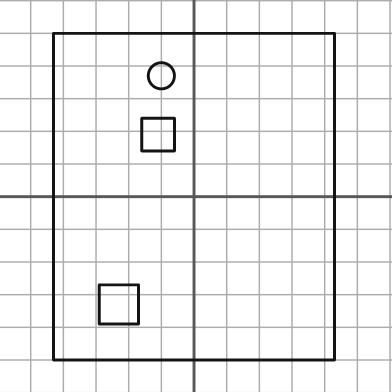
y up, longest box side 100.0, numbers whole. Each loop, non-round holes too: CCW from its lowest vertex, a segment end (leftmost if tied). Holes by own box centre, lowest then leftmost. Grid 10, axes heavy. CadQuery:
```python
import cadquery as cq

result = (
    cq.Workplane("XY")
    .moveTo(-43.0, -50.0)
    .lineTo(43.0, -50.0)
    .lineTo(43.0, 50.0)
    .lineTo(-43.0, 50.0)
    .close()
    .moveTo(-29.0, -39.0)
    .lineTo(-17.0, -39.0)
    .lineTo(-17.0, -27.0)
    .lineTo(-29.0, -27.0)
    .close()
    .moveTo(-16.0, 14.0)
    .lineTo(-6.0, 14.0)
    .lineTo(-6.0, 24.0)
    .lineTo(-16.0, 24.0)
    .close()
    .moveTo(-10.0, 37.0)
    .circle(4.0)
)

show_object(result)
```